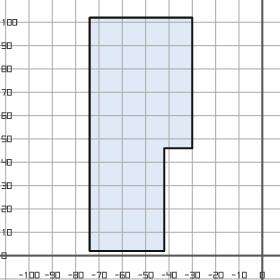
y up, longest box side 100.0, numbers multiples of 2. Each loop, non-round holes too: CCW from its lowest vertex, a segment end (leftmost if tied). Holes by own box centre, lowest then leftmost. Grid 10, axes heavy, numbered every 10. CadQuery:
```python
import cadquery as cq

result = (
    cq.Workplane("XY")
    .moveTo(-74.0, 2.0)
    .lineTo(-42.0, 2.0)
    .lineTo(-42.0, 46.0)
    .lineTo(-30.0, 46.0)
    .lineTo(-30.0, 102.0)
    .lineTo(-74.0, 102.0)
    .close()
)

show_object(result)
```